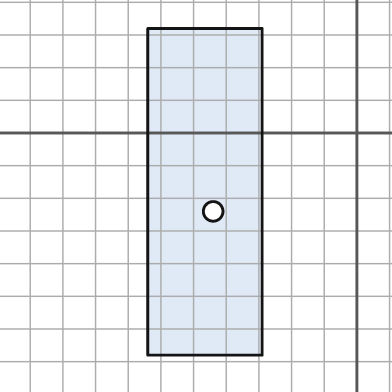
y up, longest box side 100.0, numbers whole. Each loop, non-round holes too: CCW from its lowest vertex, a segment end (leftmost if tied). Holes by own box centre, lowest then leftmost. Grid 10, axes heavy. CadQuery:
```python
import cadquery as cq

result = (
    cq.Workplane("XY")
    .moveTo(-64.0, -68.0)
    .lineTo(-29.0, -68.0)
    .lineTo(-29.0, 32.0)
    .lineTo(-64.0, 32.0)
    .close()
    .moveTo(-44.0, -24.0)
    .circle(3.0)
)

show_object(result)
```